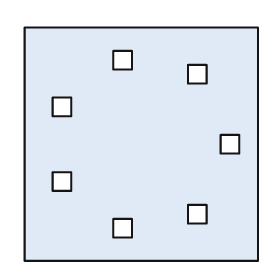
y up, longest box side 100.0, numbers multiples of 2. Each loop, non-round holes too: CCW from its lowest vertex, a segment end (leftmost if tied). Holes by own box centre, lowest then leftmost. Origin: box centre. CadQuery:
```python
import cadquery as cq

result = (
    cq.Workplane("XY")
    .moveTo(-50.0, -50.0)
    .lineTo(50.0, -50.0)
    .lineTo(50.0, 50.0)
    .lineTo(-50.0, 50.0)
    .close()
    .moveTo(-12.0, -40.0)
    .lineTo(-4.0, -40.0)
    .lineTo(-4.0, -32.0)
    .lineTo(-12.0, -32.0)
    .close()
    .moveTo(20.0, -34.0)
    .lineTo(28.0, -34.0)
    .lineTo(28.0, -26.0)
    .lineTo(20.0, -26.0)
    .close()
    .moveTo(-38.0, -20.0)
    .lineTo(-30.0, -20.0)
    .lineTo(-30.0, -12.0)
    .lineTo(-38.0, -12.0)
    .close()
    .moveTo(34.0, -4.0)
    .lineTo(42.0, -4.0)
    .lineTo(42.0, 4.0)
    .lineTo(34.0, 4.0)
    .close()
    .moveTo(-38.0, 12.0)
    .lineTo(-30.0, 12.0)
    .lineTo(-30.0, 20.0)
    .lineTo(-38.0, 20.0)
    .close()
    .moveTo(20.0, 26.0)
    .lineTo(28.0, 26.0)
    .lineTo(28.0, 34.0)
    .lineTo(20.0, 34.0)
    .close()
    .moveTo(-12.0, 32.0)
    .lineTo(-4.0, 32.0)
    .lineTo(-4.0, 40.0)
    .lineTo(-12.0, 40.0)
    .close()
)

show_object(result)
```